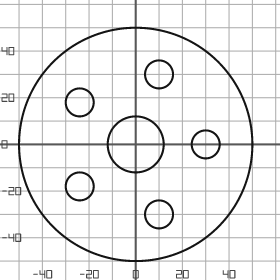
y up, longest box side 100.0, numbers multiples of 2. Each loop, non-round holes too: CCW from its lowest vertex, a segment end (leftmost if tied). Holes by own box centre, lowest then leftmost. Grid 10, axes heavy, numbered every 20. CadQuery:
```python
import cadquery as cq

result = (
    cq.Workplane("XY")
    .moveTo(0.0, 0.0)
    .circle(50.0)
    .moveTo(10.0, -30.0)
    .circle(6.0)
    .moveTo(-24.0, -18.0)
    .circle(6.0)
    .moveTo(0.0, 0.0)
    .circle(12.0)
    .moveTo(30.0, 0.0)
    .circle(6.0)
    .moveTo(-24.0, 18.0)
    .circle(6.0)
    .moveTo(10.0, 30.0)
    .circle(6.0)
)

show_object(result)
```